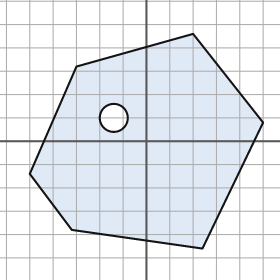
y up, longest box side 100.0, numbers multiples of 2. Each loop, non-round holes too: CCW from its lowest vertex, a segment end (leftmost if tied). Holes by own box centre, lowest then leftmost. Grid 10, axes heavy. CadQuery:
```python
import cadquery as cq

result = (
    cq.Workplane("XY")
    .moveTo(24.0, -46.0)
    .lineTo(50.0, 8.0)
    .lineTo(20.0, 46.0)
    .lineTo(-30.0, 32.0)
    .lineTo(-50.0, -14.0)
    .lineTo(-32.0, -38.0)
    .close()
    .moveTo(-14.0, 10.0)
    .circle(6.0)
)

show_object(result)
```